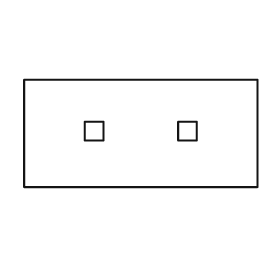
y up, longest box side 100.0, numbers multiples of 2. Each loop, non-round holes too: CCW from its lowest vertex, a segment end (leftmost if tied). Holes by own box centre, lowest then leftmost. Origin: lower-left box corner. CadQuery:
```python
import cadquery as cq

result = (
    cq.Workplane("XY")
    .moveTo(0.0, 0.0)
    .lineTo(100.0, 0.0)
    .lineTo(100.0, 46.0)
    .lineTo(0.0, 46.0)
    .close()
    .moveTo(26.0, 20.0)
    .lineTo(34.0, 20.0)
    .lineTo(34.0, 28.0)
    .lineTo(26.0, 28.0)
    .close()
    .moveTo(66.0, 20.0)
    .lineTo(74.0, 20.0)
    .lineTo(74.0, 28.0)
    .lineTo(66.0, 28.0)
    .close()
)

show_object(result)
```